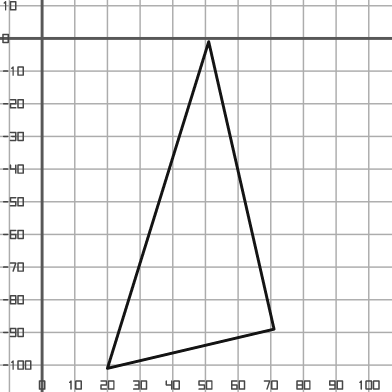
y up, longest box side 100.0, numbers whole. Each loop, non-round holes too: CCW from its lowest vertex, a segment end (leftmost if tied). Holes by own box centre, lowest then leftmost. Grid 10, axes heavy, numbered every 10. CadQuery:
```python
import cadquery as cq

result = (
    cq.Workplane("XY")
    .moveTo(20.0, -101.0)
    .lineTo(71.0, -89.0)
    .lineTo(51.0, -1.0)
    .close()
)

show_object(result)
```